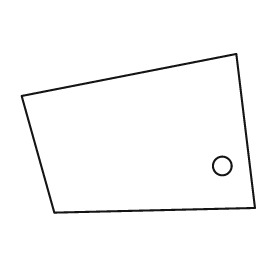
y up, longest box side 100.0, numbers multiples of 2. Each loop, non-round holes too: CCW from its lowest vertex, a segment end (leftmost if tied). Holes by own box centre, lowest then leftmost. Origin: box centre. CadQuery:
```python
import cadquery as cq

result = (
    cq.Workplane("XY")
    .moveTo(-36.0, -34.0)
    .lineTo(50.0, -32.0)
    .lineTo(42.0, 34.0)
    .lineTo(-50.0, 16.0)
    .close()
    .moveTo(36.0, -14.0)
    .circle(4.0)
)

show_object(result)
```